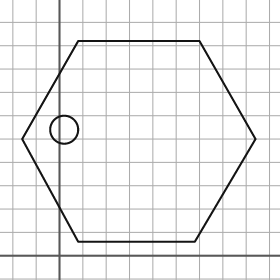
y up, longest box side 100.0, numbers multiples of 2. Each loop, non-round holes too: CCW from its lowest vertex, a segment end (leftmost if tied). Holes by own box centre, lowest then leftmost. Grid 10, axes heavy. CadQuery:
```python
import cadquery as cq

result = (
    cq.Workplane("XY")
    .moveTo(8.0, 6.0)
    .lineTo(58.0, 6.0)
    .lineTo(84.0, 50.0)
    .lineTo(60.0, 92.0)
    .lineTo(8.0, 92.0)
    .lineTo(-16.0, 50.0)
    .close()
    .moveTo(2.0, 54.0)
    .circle(6.0)
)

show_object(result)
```